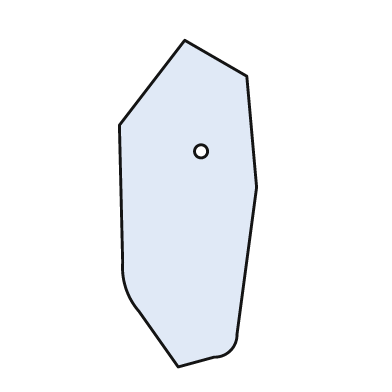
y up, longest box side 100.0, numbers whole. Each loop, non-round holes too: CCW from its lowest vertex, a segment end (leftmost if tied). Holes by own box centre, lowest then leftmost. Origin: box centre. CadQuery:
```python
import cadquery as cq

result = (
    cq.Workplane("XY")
    .moveTo(-3.0, -50.0)
    .lineTo(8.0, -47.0)
    .threePointArc((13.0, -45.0), (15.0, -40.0))
    .lineTo(21.0, 5.0)
    .lineTo(18.0, 39.0)
    .lineTo(-1.0, 50.0)
    .lineTo(-21.0, 24.0)
    .lineTo(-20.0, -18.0)
    .threePointArc((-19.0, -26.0), (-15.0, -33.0))
    .close()
    .moveTo(4.0, 16.0)
    .circle(2.0)
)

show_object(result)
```